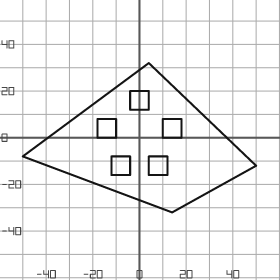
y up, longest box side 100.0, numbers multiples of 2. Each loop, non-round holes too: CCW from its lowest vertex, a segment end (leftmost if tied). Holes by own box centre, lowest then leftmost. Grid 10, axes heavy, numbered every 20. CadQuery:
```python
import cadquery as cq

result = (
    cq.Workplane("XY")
    .moveTo(14.0, -32.0)
    .lineTo(50.0, -12.0)
    .lineTo(4.0, 32.0)
    .lineTo(-50.0, -8.0)
    .close()
    .moveTo(-12.0, -16.0)
    .lineTo(-4.0, -16.0)
    .lineTo(-4.0, -8.0)
    .lineTo(-12.0, -8.0)
    .close()
    .moveTo(4.0, -16.0)
    .lineTo(12.0, -16.0)
    .lineTo(12.0, -8.0)
    .lineTo(4.0, -8.0)
    .close()
    .moveTo(-18.0, 0.0)
    .lineTo(-10.0, 0.0)
    .lineTo(-10.0, 8.0)
    .lineTo(-18.0, 8.0)
    .close()
    .moveTo(10.0, 0.0)
    .lineTo(18.0, 0.0)
    .lineTo(18.0, 8.0)
    .lineTo(10.0, 8.0)
    .close()
    .moveTo(-4.0, 12.0)
    .lineTo(4.0, 12.0)
    .lineTo(4.0, 20.0)
    .lineTo(-4.0, 20.0)
    .close()
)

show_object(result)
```